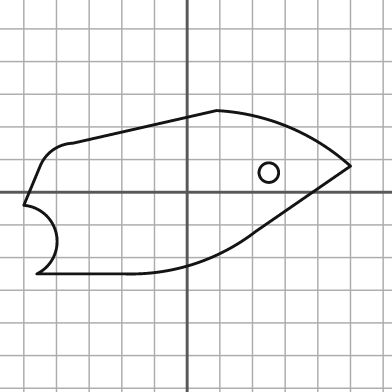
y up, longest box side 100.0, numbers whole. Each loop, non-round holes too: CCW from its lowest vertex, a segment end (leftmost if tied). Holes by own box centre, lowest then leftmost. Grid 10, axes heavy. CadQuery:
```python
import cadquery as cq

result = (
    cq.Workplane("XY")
    .moveTo(-46.0, -25.0)
    .lineTo(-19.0, -25.0)
    .threePointArc((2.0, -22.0), (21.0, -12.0))
    .lineTo(50.0, 8.0)
    .threePointArc((31.0, 20.0), (9.0, 25.0))
    .lineTo(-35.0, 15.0)
    .threePointArc((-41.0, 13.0), (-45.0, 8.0))
    .lineTo(-50.0, -4.0)
    .threePointArc((-40.0, -13.0), (-46.0, -25.0))
    .close()
    .moveTo(25.0, 6.0)
    .circle(3.0)
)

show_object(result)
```